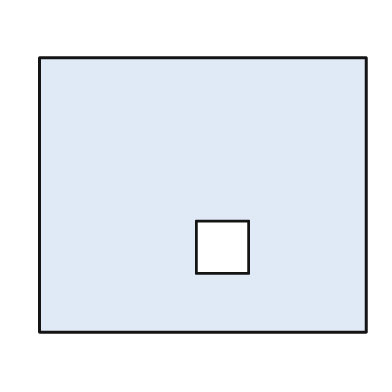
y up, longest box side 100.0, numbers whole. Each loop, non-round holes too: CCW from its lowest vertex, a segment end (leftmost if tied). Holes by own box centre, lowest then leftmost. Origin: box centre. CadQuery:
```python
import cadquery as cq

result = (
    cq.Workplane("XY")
    .moveTo(-50.0, -42.0)
    .lineTo(50.0, -42.0)
    .lineTo(50.0, 42.0)
    .lineTo(-50.0, 42.0)
    .close()
    .moveTo(-2.0, -24.0)
    .lineTo(14.0, -24.0)
    .lineTo(14.0, -8.0)
    .lineTo(-2.0, -8.0)
    .close()
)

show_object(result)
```